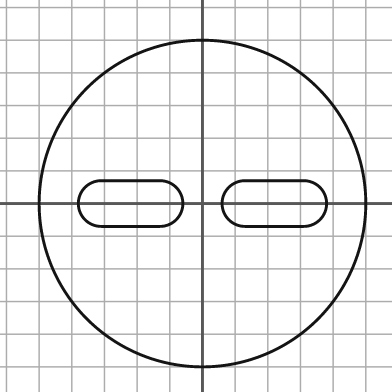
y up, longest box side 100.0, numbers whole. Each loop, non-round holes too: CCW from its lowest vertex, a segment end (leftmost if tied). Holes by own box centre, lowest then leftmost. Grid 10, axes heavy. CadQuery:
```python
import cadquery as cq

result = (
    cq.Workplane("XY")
    .moveTo(0.0, 0.0)
    .circle(50.0)
    .moveTo(-31.0, -7.0)
    .lineTo(-13.0, -7.0)
    .threePointArc((-6.0, 0.0), (-13.0, 7.0))
    .lineTo(-31.0, 7.0)
    .threePointArc((-38.0, 0.0), (-31.0, -7.0))
    .close()
    .moveTo(13.0, -7.0)
    .lineTo(31.0, -7.0)
    .threePointArc((38.0, 0.0), (31.0, 7.0))
    .lineTo(13.0, 7.0)
    .threePointArc((6.0, 0.0), (13.0, -7.0))
    .close()
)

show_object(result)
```